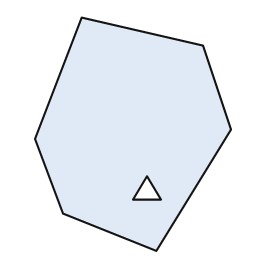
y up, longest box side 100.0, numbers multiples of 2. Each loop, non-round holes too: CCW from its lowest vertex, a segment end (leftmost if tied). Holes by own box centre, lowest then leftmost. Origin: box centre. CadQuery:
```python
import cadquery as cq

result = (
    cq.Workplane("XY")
    .moveTo(10.0, -50.0)
    .lineTo(42.0, 2.0)
    .lineTo(30.0, 38.0)
    .lineTo(-22.0, 50.0)
    .lineTo(-42.0, -2.0)
    .lineTo(-30.0, -34.0)
    .close()
    .moveTo(0.0, -28.0)
    .lineTo(12.0, -28.0)
    .lineTo(6.0, -18.0)
    .close()
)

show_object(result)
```